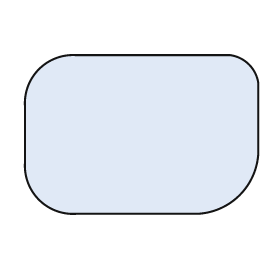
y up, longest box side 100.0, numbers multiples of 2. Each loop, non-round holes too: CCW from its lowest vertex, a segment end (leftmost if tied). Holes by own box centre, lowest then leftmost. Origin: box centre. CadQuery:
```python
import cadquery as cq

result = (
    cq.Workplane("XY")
    .moveTo(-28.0, -34.0)
    .lineTo(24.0, -34.0)
    .threePointArc((42.0, -26.0), (50.0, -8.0))
    .lineTo(50.0, 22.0)
    .threePointArc((46.0, 30.0), (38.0, 34.0))
    .lineTo(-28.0, 34.0)
    .threePointArc((-44.0, 28.0), (-50.0, 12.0))
    .lineTo(-50.0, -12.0)
    .threePointArc((-44.0, -28.0), (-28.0, -34.0))
    .close()
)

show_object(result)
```